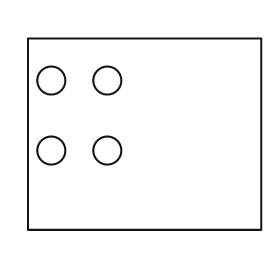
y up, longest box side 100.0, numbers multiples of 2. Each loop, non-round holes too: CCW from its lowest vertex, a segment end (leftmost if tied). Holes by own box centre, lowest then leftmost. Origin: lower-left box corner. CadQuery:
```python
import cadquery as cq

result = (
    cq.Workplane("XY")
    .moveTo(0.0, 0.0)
    .lineTo(100.0, 0.0)
    .lineTo(100.0, 82.0)
    .lineTo(0.0, 82.0)
    .close()
    .moveTo(10.0, 34.0)
    .circle(6.0)
    .moveTo(34.0, 34.0)
    .circle(6.0)
    .moveTo(10.0, 64.0)
    .circle(6.0)
    .moveTo(34.0, 64.0)
    .circle(6.0)
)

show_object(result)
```